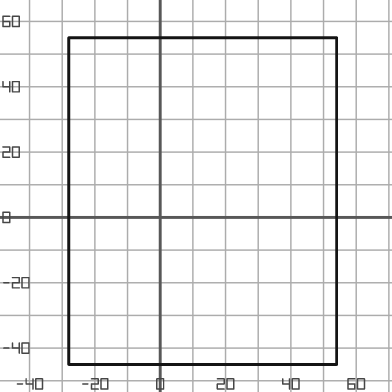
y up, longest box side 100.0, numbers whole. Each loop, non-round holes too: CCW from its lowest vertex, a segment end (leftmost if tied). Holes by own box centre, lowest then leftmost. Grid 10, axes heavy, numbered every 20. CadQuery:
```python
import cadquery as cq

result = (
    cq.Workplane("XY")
    .moveTo(-28.0, -45.0)
    .lineTo(54.0, -45.0)
    .lineTo(54.0, 55.0)
    .lineTo(-28.0, 55.0)
    .close()
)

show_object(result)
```